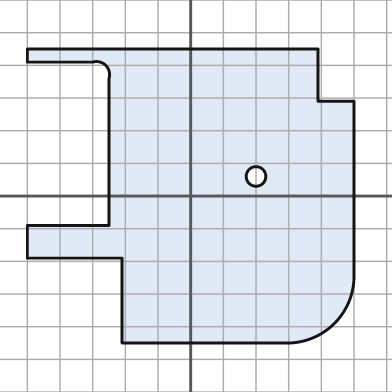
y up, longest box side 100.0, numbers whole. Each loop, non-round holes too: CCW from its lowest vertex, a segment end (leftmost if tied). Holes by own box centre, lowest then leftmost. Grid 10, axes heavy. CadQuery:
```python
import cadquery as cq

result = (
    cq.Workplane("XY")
    .moveTo(-21.0, -45.0)
    .lineTo(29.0, -45.0)
    .threePointArc((44.0, -39.0), (50.0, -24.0))
    .lineTo(50.0, 29.0)
    .lineTo(39.0, 29.0)
    .lineTo(39.0, 45.0)
    .lineTo(-50.0, 45.0)
    .lineTo(-50.0, 41.0)
    .lineTo(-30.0, 41.0)
    .threePointArc((-26.0, 40.0), (-25.0, 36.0))
    .lineTo(-25.0, -9.0)
    .lineTo(-50.0, -9.0)
    .lineTo(-50.0, -19.0)
    .lineTo(-21.0, -19.0)
    .close()
    .moveTo(20.0, 6.0)
    .circle(3.0)
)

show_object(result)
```